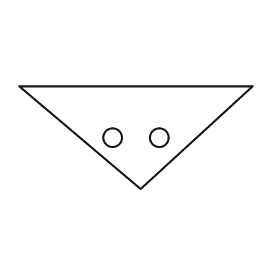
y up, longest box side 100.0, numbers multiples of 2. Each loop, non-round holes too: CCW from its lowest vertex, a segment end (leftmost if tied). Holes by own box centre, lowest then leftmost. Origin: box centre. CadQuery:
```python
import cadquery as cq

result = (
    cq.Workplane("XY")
    .moveTo(2.0, -22.0)
    .lineTo(50.0, 22.0)
    .lineTo(-50.0, 22.0)
    .close()
    .moveTo(-10.0, 0.0)
    .circle(4.0)
    .moveTo(10.0, 0.0)
    .circle(4.0)
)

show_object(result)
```